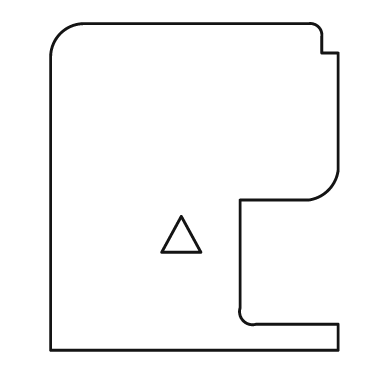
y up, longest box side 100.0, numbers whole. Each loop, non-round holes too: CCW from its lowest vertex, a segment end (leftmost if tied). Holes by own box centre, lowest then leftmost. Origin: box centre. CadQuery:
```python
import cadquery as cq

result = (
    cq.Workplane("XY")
    .moveTo(-44.0, -50.0)
    .lineTo(44.0, -50.0)
    .lineTo(44.0, -42.0)
    .lineTo(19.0, -42.0)
    .threePointArc((15.0, -41.0), (14.0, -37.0))
    .lineTo(14.0, -4.0)
    .lineTo(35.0, -4.0)
    .threePointArc((41.0, -1.0), (44.0, 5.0))
    .lineTo(44.0, 41.0)
    .lineTo(39.0, 41.0)
    .lineTo(39.0, 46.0)
    .threePointArc((38.0, 49.0), (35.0, 50.0))
    .lineTo(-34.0, 50.0)
    .threePointArc((-41.0, 47.0), (-44.0, 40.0))
    .close()
    .moveTo(-10.0, -20.0)
    .lineTo(2.0, -20.0)
    .lineTo(-4.0, -9.0)
    .close()
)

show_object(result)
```